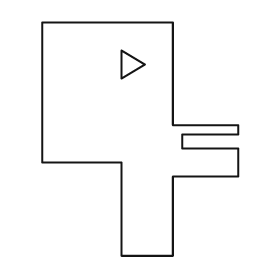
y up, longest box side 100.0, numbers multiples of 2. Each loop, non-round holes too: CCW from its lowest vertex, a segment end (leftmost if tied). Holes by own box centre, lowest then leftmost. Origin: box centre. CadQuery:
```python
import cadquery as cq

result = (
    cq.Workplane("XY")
    .moveTo(-8.0, -50.0)
    .lineTo(14.0, -50.0)
    .lineTo(14.0, -16.0)
    .lineTo(42.0, -16.0)
    .lineTo(42.0, -4.0)
    .lineTo(18.0, -4.0)
    .lineTo(18.0, 2.0)
    .lineTo(42.0, 2.0)
    .lineTo(42.0, 6.0)
    .lineTo(14.0, 6.0)
    .lineTo(14.0, 50.0)
    .lineTo(-42.0, 50.0)
    .lineTo(-42.0, -10.0)
    .lineTo(-8.0, -10.0)
    .close()
    .moveTo(-8.0, 26.0)
    .lineTo(2.0, 32.0)
    .lineTo(-8.0, 38.0)
    .close()
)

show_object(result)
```